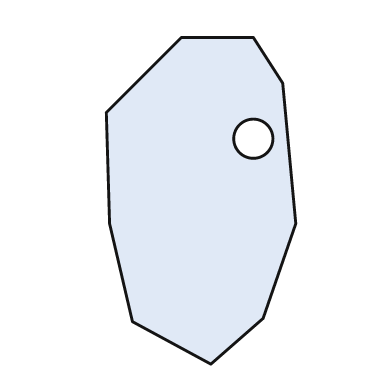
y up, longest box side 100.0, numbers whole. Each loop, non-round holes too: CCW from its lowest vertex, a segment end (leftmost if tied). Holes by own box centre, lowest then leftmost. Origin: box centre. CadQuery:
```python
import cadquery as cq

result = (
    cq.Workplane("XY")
    .moveTo(3.0, -50.0)
    .lineTo(19.0, -36.0)
    .lineTo(29.0, -7.0)
    .lineTo(25.0, 36.0)
    .lineTo(16.0, 50.0)
    .lineTo(-6.0, 50.0)
    .lineTo(-29.0, 27.0)
    .lineTo(-28.0, -7.0)
    .lineTo(-21.0, -37.0)
    .close()
    .moveTo(16.0, 19.0)
    .circle(6.0)
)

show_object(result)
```